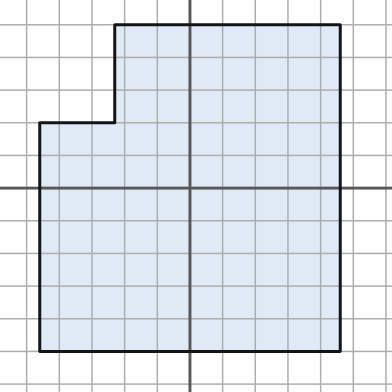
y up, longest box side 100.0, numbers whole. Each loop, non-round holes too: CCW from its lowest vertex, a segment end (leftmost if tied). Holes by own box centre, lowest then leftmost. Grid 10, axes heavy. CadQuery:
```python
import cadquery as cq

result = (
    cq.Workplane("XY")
    .moveTo(-46.0, -50.0)
    .lineTo(46.0, -50.0)
    .lineTo(46.0, 50.0)
    .lineTo(-23.0, 50.0)
    .lineTo(-23.0, 20.0)
    .lineTo(-46.0, 20.0)
    .close()
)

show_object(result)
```